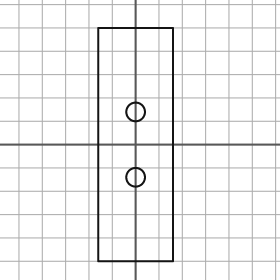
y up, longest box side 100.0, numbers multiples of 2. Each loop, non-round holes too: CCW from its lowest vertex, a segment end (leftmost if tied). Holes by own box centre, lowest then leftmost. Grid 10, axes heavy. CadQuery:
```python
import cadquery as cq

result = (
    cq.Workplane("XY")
    .moveTo(-16.0, -50.0)
    .lineTo(16.0, -50.0)
    .lineTo(16.0, 50.0)
    .lineTo(-16.0, 50.0)
    .close()
    .moveTo(0.0, -14.0)
    .circle(4.0)
    .moveTo(0.0, 14.0)
    .circle(4.0)
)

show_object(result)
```